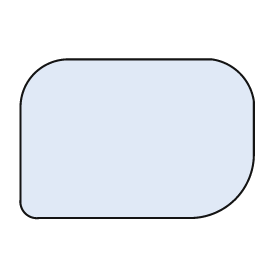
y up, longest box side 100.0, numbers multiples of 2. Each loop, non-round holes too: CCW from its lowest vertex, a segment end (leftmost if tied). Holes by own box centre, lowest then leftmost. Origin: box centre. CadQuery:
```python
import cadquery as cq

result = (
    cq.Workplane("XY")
    .moveTo(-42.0, -34.0)
    .lineTo(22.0, -34.0)
    .threePointArc((42.0, -26.0), (50.0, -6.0))
    .lineTo(50.0, 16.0)
    .threePointArc((44.0, 28.0), (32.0, 34.0))
    .lineTo(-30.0, 34.0)
    .threePointArc((-44.0, 28.0), (-50.0, 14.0))
    .lineTo(-50.0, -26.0)
    .threePointArc((-48.0, -32.0), (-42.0, -34.0))
    .close()
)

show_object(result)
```